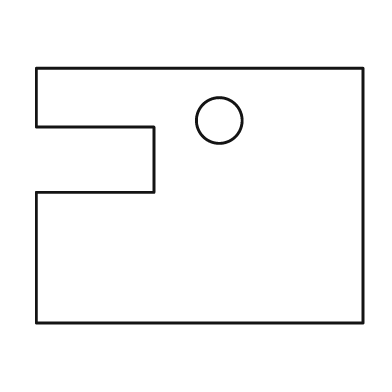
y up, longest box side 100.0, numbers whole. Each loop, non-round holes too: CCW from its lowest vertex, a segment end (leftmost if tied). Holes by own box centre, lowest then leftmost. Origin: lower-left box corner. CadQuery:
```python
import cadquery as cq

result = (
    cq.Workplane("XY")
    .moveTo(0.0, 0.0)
    .lineTo(100.0, 0.0)
    .lineTo(100.0, 78.0)
    .lineTo(0.0, 78.0)
    .lineTo(0.0, 60.0)
    .lineTo(36.0, 60.0)
    .lineTo(36.0, 40.0)
    .lineTo(0.0, 40.0)
    .close()
    .moveTo(56.0, 62.0)
    .circle(7.0)
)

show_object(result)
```